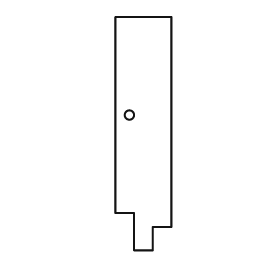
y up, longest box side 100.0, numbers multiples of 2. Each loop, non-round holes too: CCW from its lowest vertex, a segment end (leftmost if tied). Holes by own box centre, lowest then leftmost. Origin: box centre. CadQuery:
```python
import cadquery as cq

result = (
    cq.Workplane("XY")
    .moveTo(-4.0, -50.0)
    .lineTo(4.0, -50.0)
    .lineTo(4.0, -40.0)
    .lineTo(12.0, -40.0)
    .lineTo(12.0, 50.0)
    .lineTo(-12.0, 50.0)
    .lineTo(-12.0, -34.0)
    .lineTo(-4.0, -34.0)
    .close()
    .moveTo(-6.0, 8.0)
    .circle(2.0)
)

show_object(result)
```